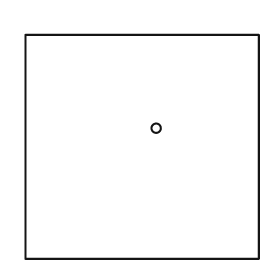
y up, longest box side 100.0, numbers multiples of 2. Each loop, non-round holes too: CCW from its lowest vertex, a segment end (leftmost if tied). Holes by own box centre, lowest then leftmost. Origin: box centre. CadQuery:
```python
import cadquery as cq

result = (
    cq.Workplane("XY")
    .moveTo(-50.0, -48.0)
    .lineTo(50.0, -48.0)
    .lineTo(50.0, 48.0)
    .lineTo(-50.0, 48.0)
    .close()
    .moveTo(6.0, 8.0)
    .circle(2.0)
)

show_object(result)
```